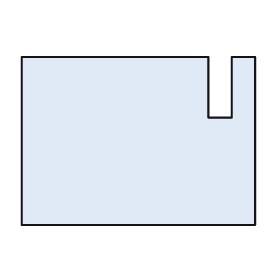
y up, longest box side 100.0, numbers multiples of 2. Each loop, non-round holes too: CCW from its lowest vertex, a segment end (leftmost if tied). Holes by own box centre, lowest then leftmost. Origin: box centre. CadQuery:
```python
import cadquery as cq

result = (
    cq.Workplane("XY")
    .moveTo(-50.0, -36.0)
    .lineTo(50.0, -36.0)
    .lineTo(50.0, 36.0)
    .lineTo(40.0, 36.0)
    .lineTo(40.0, 10.0)
    .lineTo(30.0, 10.0)
    .lineTo(30.0, 36.0)
    .lineTo(-50.0, 36.0)
    .close()
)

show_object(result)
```